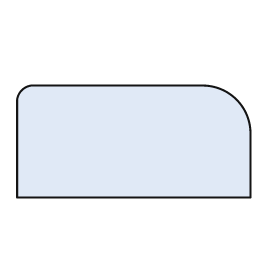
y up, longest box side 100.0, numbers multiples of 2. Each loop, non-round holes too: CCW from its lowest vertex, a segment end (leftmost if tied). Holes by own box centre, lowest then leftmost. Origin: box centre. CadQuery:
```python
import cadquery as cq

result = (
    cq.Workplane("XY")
    .moveTo(-50.0, -24.0)
    .lineTo(50.0, -24.0)
    .lineTo(50.0, 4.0)
    .threePointArc((44.0, 18.0), (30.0, 24.0))
    .lineTo(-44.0, 24.0)
    .threePointArc((-48.0, 22.0), (-50.0, 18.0))
    .close()
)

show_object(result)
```